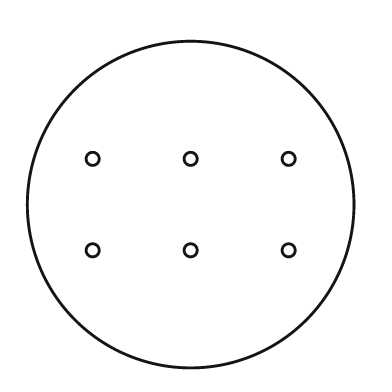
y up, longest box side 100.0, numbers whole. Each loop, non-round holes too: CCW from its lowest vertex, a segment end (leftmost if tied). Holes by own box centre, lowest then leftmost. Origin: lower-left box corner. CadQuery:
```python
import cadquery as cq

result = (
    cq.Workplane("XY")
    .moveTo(50.0, 50.0)
    .circle(50.0)
    .moveTo(20.0, 36.0)
    .circle(2.0)
    .moveTo(50.0, 36.0)
    .circle(2.0)
    .moveTo(80.0, 36.0)
    .circle(2.0)
    .moveTo(20.0, 64.0)
    .circle(2.0)
    .moveTo(50.0, 64.0)
    .circle(2.0)
    .moveTo(80.0, 64.0)
    .circle(2.0)
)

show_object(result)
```